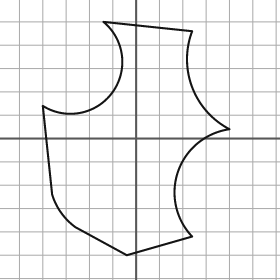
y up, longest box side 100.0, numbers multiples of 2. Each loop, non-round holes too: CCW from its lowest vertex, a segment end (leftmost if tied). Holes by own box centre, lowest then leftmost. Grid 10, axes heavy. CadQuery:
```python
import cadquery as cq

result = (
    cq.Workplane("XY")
    .moveTo(-4.0, -50.0)
    .lineTo(24.0, -42.0)
    .threePointArc((18.0, -14.0), (40.0, 4.0))
    .threePointArc((24.0, 22.0), (24.0, 46.0))
    .lineTo(-14.0, 50.0)
    .threePointArc((-10.0, 20.0), (-40.0, 14.0))
    .lineTo(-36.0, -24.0)
    .threePointArc((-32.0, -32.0), (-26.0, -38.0))
    .close()
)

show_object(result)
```